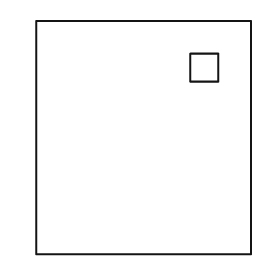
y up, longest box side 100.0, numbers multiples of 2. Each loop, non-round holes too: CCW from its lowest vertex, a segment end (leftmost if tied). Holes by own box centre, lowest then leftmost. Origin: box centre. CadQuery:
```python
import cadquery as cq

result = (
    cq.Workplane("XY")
    .moveTo(-46.0, -50.0)
    .lineTo(46.0, -50.0)
    .lineTo(46.0, 50.0)
    .lineTo(-46.0, 50.0)
    .close()
    .moveTo(20.0, 24.0)
    .lineTo(32.0, 24.0)
    .lineTo(32.0, 36.0)
    .lineTo(20.0, 36.0)
    .close()
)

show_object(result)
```